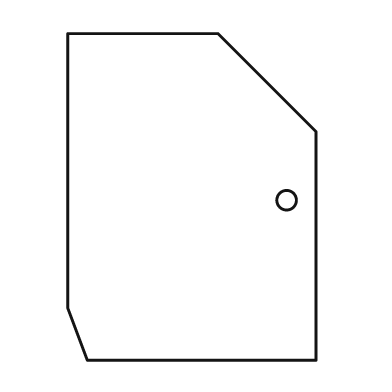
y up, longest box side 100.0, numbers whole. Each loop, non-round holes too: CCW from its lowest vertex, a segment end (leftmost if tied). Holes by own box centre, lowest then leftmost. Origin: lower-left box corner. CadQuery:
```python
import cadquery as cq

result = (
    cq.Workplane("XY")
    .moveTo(6.0, 0.0)
    .lineTo(76.0, 0.0)
    .lineTo(76.0, 70.0)
    .lineTo(46.0, 100.0)
    .lineTo(0.0, 100.0)
    .lineTo(0.0, 16.0)
    .close()
    .moveTo(67.0, 49.0)
    .circle(3.0)
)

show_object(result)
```